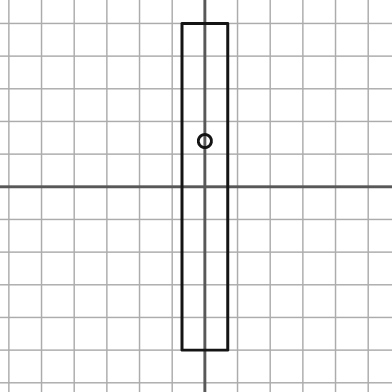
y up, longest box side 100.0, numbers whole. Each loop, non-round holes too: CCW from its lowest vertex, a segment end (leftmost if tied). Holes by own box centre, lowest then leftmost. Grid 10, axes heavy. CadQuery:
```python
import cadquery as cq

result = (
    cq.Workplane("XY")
    .moveTo(-7.0, -50.0)
    .lineTo(7.0, -50.0)
    .lineTo(7.0, 50.0)
    .lineTo(-7.0, 50.0)
    .close()
    .moveTo(0.0, 14.0)
    .circle(2.0)
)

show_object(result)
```